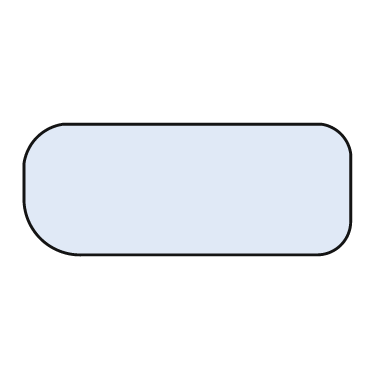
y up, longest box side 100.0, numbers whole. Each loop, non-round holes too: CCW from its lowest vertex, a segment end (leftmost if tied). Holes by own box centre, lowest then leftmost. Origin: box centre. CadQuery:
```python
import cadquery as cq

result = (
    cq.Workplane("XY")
    .moveTo(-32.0, -20.0)
    .lineTo(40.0, -20.0)
    .threePointArc((47.0, -17.0), (50.0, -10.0))
    .lineTo(50.0, 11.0)
    .threePointArc((47.0, 17.0), (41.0, 20.0))
    .lineTo(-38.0, 20.0)
    .threePointArc((-46.0, 16.0), (-50.0, 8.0))
    .lineTo(-50.0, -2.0)
    .threePointArc((-45.0, -15.0), (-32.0, -20.0))
    .close()
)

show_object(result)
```